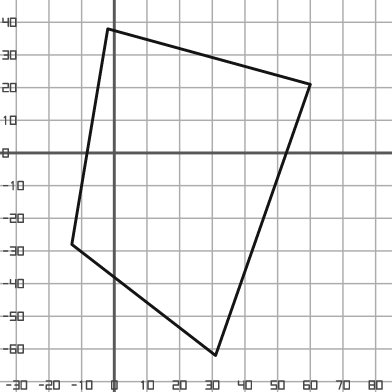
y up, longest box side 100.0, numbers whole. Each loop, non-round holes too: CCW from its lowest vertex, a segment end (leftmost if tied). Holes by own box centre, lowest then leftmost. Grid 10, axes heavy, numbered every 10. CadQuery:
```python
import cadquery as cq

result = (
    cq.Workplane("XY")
    .moveTo(31.0, -62.0)
    .lineTo(60.0, 21.0)
    .lineTo(-2.0, 38.0)
    .lineTo(-13.0, -28.0)
    .close()
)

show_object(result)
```